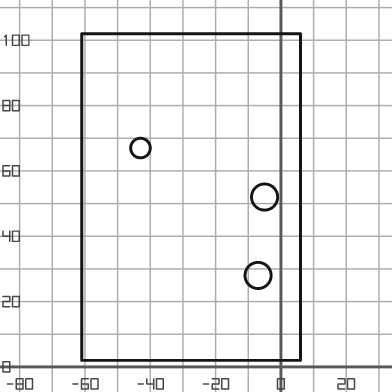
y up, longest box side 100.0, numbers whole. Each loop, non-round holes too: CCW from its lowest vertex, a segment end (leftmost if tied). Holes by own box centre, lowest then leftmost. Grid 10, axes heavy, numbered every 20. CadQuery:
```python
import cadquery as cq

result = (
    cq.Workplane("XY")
    .moveTo(-61.0, 2.0)
    .lineTo(6.0, 2.0)
    .lineTo(6.0, 102.0)
    .lineTo(-61.0, 102.0)
    .close()
    .moveTo(-7.0, 28.0)
    .circle(4.0)
    .moveTo(-5.0, 52.0)
    .circle(4.0)
    .moveTo(-43.0, 67.0)
    .circle(3.0)
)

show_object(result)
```